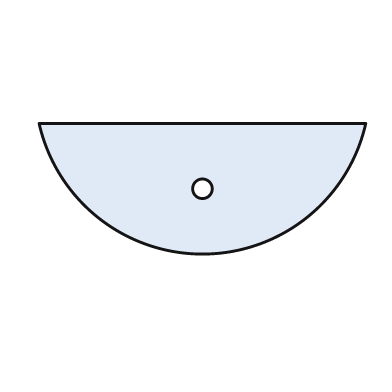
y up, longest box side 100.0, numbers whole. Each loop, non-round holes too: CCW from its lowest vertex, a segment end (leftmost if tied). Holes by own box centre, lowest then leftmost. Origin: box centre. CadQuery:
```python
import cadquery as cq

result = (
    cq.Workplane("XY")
    .moveTo(-50.0, 20.0)
    .threePointArc((0.0, -20.0), (50.0, 20.0))
    .close()
    .moveTo(0.0, 0.0)
    .circle(3.0)
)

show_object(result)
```